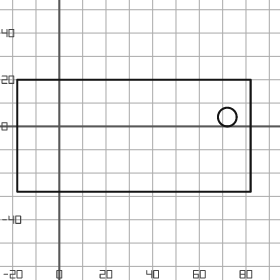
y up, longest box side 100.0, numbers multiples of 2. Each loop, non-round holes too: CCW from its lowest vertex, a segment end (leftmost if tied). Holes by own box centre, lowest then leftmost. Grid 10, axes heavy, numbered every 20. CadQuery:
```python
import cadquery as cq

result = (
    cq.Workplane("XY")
    .moveTo(-18.0, -28.0)
    .lineTo(82.0, -28.0)
    .lineTo(82.0, 20.0)
    .lineTo(-18.0, 20.0)
    .close()
    .moveTo(72.0, 4.0)
    .circle(4.0)
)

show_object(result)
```